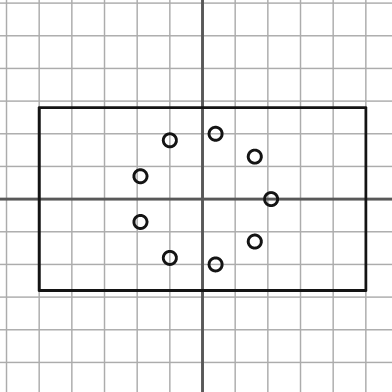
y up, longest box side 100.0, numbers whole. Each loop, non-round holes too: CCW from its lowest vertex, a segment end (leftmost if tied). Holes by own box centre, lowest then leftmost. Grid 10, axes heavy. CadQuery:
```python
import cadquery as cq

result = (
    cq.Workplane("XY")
    .moveTo(-50.0, -28.0)
    .lineTo(50.0, -28.0)
    .lineTo(50.0, 28.0)
    .lineTo(-50.0, 28.0)
    .close()
    .moveTo(4.0, -20.0)
    .circle(2.0)
    .moveTo(-10.0, -18.0)
    .circle(2.0)
    .moveTo(16.0, -13.0)
    .circle(2.0)
    .moveTo(-19.0, -7.0)
    .circle(2.0)
    .moveTo(21.0, 0.0)
    .circle(2.0)
    .moveTo(-19.0, 7.0)
    .circle(2.0)
    .moveTo(16.0, 13.0)
    .circle(2.0)
    .moveTo(-10.0, 18.0)
    .circle(2.0)
    .moveTo(4.0, 20.0)
    .circle(2.0)
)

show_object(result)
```